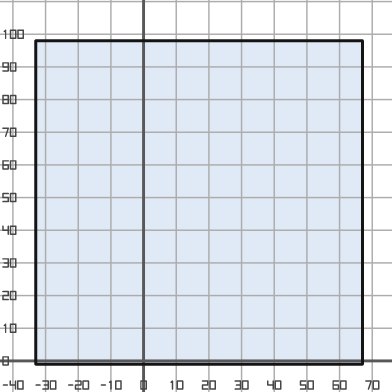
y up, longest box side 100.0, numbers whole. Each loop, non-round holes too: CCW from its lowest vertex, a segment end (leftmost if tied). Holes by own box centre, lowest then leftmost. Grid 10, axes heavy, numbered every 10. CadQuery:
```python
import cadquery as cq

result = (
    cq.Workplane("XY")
    .moveTo(-33.0, -1.0)
    .lineTo(67.0, -1.0)
    .lineTo(67.0, 98.0)
    .lineTo(-33.0, 98.0)
    .close()
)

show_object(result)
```